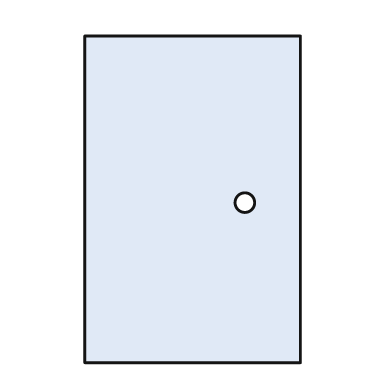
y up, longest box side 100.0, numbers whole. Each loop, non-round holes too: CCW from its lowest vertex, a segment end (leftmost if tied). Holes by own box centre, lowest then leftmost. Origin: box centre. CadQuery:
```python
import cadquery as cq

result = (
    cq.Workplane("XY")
    .moveTo(-33.0, -50.0)
    .lineTo(33.0, -50.0)
    .lineTo(33.0, 50.0)
    .lineTo(-33.0, 50.0)
    .close()
    .moveTo(16.0, -1.0)
    .circle(3.0)
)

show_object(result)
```